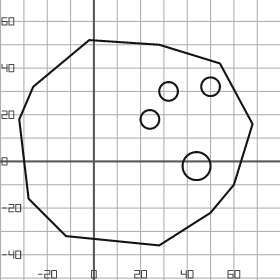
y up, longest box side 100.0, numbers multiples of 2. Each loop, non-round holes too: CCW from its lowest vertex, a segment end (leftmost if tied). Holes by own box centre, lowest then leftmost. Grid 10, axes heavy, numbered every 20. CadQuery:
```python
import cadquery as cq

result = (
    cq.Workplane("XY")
    .moveTo(28.0, -36.0)
    .lineTo(50.0, -22.0)
    .lineTo(60.0, -10.0)
    .lineTo(68.0, 16.0)
    .lineTo(54.0, 42.0)
    .lineTo(28.0, 50.0)
    .lineTo(-2.0, 52.0)
    .lineTo(-26.0, 32.0)
    .lineTo(-32.0, 18.0)
    .lineTo(-28.0, -16.0)
    .lineTo(-12.0, -32.0)
    .close()
    .moveTo(44.0, -2.0)
    .circle(6.0)
    .moveTo(24.0, 18.0)
    .circle(4.0)
    .moveTo(32.0, 30.0)
    .circle(4.0)
    .moveTo(50.0, 32.0)
    .circle(4.0)
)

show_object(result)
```